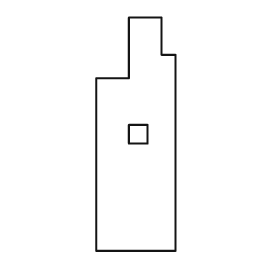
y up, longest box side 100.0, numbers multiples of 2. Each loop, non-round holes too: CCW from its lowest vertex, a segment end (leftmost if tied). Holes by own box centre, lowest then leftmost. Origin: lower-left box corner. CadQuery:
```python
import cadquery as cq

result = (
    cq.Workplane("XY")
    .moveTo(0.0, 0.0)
    .lineTo(34.0, 0.0)
    .lineTo(34.0, 84.0)
    .lineTo(28.0, 84.0)
    .lineTo(28.0, 100.0)
    .lineTo(14.0, 100.0)
    .lineTo(14.0, 74.0)
    .lineTo(0.0, 74.0)
    .close()
    .moveTo(14.0, 46.0)
    .lineTo(22.0, 46.0)
    .lineTo(22.0, 54.0)
    .lineTo(14.0, 54.0)
    .close()
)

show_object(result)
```